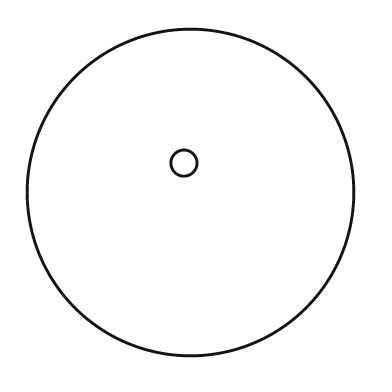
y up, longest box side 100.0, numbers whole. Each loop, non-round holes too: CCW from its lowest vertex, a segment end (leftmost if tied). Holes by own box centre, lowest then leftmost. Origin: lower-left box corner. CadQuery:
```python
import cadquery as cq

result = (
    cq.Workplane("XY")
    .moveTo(50.0, 50.0)
    .circle(50.0)
    .moveTo(48.0, 59.0)
    .circle(4.0)
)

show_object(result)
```